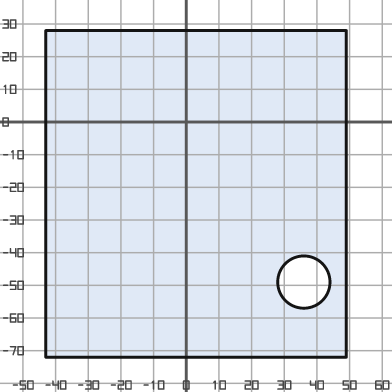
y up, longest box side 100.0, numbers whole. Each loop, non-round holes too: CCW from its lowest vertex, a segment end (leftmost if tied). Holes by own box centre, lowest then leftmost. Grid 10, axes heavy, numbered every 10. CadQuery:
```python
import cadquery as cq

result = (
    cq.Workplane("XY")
    .moveTo(-43.0, -72.0)
    .lineTo(49.0, -72.0)
    .lineTo(49.0, 28.0)
    .lineTo(-43.0, 28.0)
    .close()
    .moveTo(36.0, -49.0)
    .circle(8.0)
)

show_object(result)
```